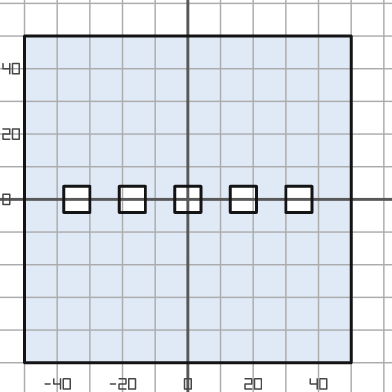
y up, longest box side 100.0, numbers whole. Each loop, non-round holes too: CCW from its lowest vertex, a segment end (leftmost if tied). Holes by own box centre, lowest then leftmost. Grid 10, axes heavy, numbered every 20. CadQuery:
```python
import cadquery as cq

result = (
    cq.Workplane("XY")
    .moveTo(-50.0, -50.0)
    .lineTo(50.0, -50.0)
    .lineTo(50.0, 50.0)
    .lineTo(-50.0, 50.0)
    .close()
    .moveTo(-38.0, -4.0)
    .lineTo(-30.0, -4.0)
    .lineTo(-30.0, 4.0)
    .lineTo(-38.0, 4.0)
    .close()
    .moveTo(-21.0, -4.0)
    .lineTo(-13.0, -4.0)
    .lineTo(-13.0, 4.0)
    .lineTo(-21.0, 4.0)
    .close()
    .moveTo(-4.0, -4.0)
    .lineTo(4.0, -4.0)
    .lineTo(4.0, 4.0)
    .lineTo(-4.0, 4.0)
    .close()
    .moveTo(13.0, -4.0)
    .lineTo(21.0, -4.0)
    .lineTo(21.0, 4.0)
    .lineTo(13.0, 4.0)
    .close()
    .moveTo(30.0, -4.0)
    .lineTo(38.0, -4.0)
    .lineTo(38.0, 4.0)
    .lineTo(30.0, 4.0)
    .close()
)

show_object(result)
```